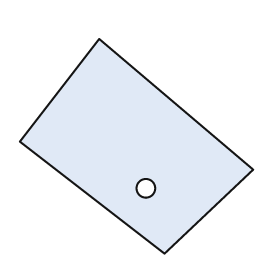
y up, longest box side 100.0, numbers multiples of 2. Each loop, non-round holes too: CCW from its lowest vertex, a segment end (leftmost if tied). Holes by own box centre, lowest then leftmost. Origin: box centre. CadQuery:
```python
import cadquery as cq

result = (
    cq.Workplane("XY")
    .moveTo(12.0, -46.0)
    .lineTo(50.0, -10.0)
    .lineTo(-16.0, 46.0)
    .lineTo(-50.0, 2.0)
    .close()
    .moveTo(4.0, -18.0)
    .circle(4.0)
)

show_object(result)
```